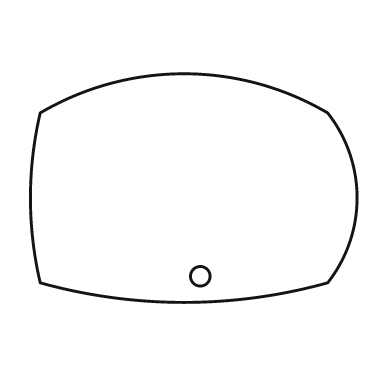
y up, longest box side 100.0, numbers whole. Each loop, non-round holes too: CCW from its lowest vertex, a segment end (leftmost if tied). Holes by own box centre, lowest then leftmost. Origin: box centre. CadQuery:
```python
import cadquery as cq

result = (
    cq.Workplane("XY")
    .moveTo(-47.0, -29.0)
    .threePointArc((-3.0, -35.0), (41.0, -29.0))
    .threePointArc((50.0, -3.0), (41.0, 23.0))
    .threePointArc((-3.0, 35.0), (-47.0, 23.0))
    .threePointArc((-50.0, -3.0), (-47.0, -29.0))
    .close()
    .moveTo(2.0, -27.0)
    .circle(3.0)
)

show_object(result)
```